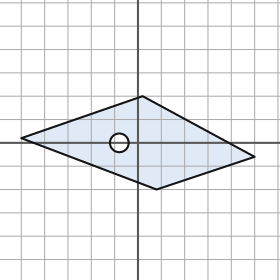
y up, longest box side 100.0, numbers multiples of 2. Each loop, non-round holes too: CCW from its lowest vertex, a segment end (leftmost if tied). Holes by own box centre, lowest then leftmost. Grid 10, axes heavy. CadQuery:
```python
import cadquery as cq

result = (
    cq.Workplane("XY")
    .moveTo(8.0, -20.0)
    .lineTo(50.0, -6.0)
    .lineTo(2.0, 20.0)
    .lineTo(-50.0, 2.0)
    .close()
    .moveTo(-8.0, 0.0)
    .circle(4.0)
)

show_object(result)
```